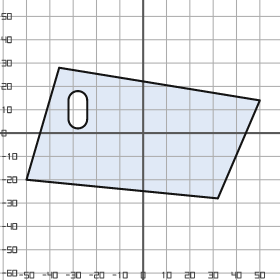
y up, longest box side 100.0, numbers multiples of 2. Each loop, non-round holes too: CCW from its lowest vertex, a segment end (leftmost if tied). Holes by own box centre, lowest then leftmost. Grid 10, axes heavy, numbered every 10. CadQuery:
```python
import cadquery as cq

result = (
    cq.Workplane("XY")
    .moveTo(32.0, -28.0)
    .lineTo(50.0, 14.0)
    .lineTo(-36.0, 28.0)
    .lineTo(-50.0, -20.0)
    .close()
    .moveTo(-32.0, 6.0)
    .threePointArc((-28.0, 2.0), (-24.0, 6.0))
    .lineTo(-24.0, 14.0)
    .threePointArc((-28.0, 18.0), (-32.0, 14.0))
    .close()
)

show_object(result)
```